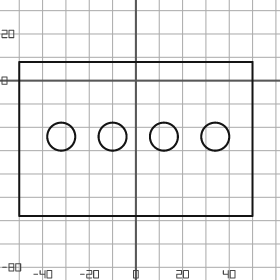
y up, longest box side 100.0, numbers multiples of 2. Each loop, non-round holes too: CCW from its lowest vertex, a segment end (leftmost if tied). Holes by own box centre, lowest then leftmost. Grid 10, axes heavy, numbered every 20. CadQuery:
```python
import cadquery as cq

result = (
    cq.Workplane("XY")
    .moveTo(-50.0, -58.0)
    .lineTo(50.0, -58.0)
    .lineTo(50.0, 8.0)
    .lineTo(-50.0, 8.0)
    .close()
    .moveTo(-32.0, -24.0)
    .circle(6.0)
    .moveTo(-10.0, -24.0)
    .circle(6.0)
    .moveTo(12.0, -24.0)
    .circle(6.0)
    .moveTo(34.0, -24.0)
    .circle(6.0)
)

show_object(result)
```